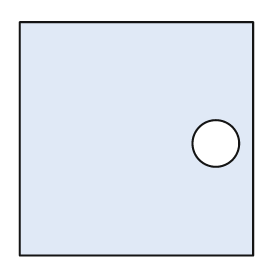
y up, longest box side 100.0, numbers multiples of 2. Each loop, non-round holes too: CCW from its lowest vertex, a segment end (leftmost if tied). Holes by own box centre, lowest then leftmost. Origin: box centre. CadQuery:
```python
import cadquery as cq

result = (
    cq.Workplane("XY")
    .moveTo(-50.0, -50.0)
    .lineTo(50.0, -50.0)
    .lineTo(50.0, 50.0)
    .lineTo(-50.0, 50.0)
    .close()
    .moveTo(34.0, -2.0)
    .circle(10.0)
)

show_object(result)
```